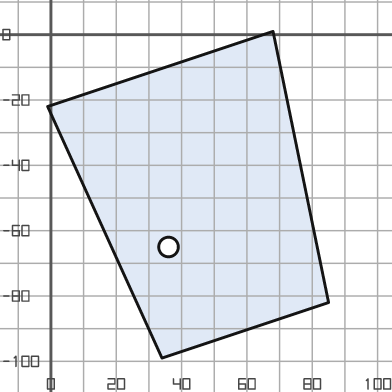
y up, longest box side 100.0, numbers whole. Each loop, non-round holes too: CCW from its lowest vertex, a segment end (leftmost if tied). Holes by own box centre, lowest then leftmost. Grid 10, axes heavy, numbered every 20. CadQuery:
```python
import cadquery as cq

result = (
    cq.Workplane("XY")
    .moveTo(34.0, -99.0)
    .lineTo(85.0, -82.0)
    .lineTo(68.0, 1.0)
    .lineTo(-1.0, -22.0)
    .close()
    .moveTo(36.0, -65.0)
    .circle(3.0)
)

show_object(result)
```